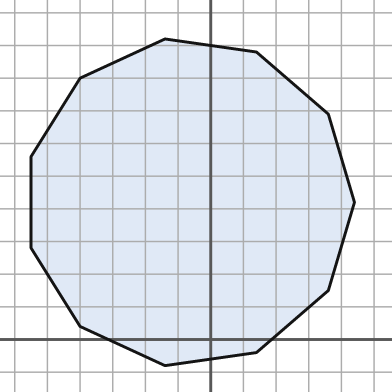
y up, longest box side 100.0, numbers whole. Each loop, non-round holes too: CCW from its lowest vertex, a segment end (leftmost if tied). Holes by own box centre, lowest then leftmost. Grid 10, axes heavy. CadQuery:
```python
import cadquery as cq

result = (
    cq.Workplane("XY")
    .moveTo(-14.0, -8.0)
    .lineTo(14.0, -4.0)
    .lineTo(36.0, 15.0)
    .lineTo(44.0, 42.0)
    .lineTo(36.0, 69.0)
    .lineTo(14.0, 88.0)
    .lineTo(-14.0, 92.0)
    .lineTo(-40.0, 80.0)
    .lineTo(-55.0, 56.0)
    .lineTo(-55.0, 28.0)
    .lineTo(-40.0, 4.0)
    .close()
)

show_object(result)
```